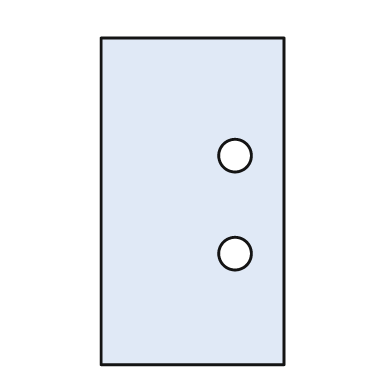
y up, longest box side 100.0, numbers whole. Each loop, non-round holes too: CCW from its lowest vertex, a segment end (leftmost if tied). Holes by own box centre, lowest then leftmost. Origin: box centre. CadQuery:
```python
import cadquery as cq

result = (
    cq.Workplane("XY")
    .moveTo(-28.0, -50.0)
    .lineTo(28.0, -50.0)
    .lineTo(28.0, 50.0)
    .lineTo(-28.0, 50.0)
    .close()
    .moveTo(13.0, -16.0)
    .circle(5.0)
    .moveTo(13.0, 14.0)
    .circle(5.0)
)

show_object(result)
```